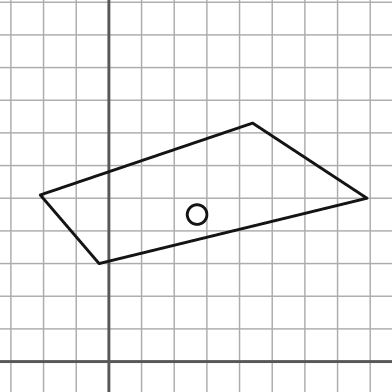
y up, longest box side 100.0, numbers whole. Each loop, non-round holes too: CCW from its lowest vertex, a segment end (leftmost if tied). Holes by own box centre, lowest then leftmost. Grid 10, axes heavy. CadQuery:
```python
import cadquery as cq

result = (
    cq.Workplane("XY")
    .moveTo(-3.0, 30.0)
    .lineTo(79.0, 50.0)
    .lineTo(44.0, 73.0)
    .lineTo(-21.0, 51.0)
    .close()
    .moveTo(27.0, 45.0)
    .circle(3.0)
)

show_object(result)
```